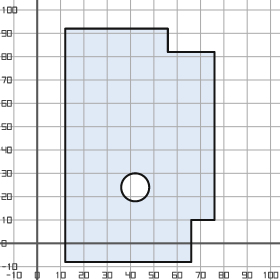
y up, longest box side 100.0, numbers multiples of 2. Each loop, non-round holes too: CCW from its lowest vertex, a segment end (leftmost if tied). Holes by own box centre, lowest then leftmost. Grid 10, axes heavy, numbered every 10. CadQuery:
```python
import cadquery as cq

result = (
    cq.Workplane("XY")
    .moveTo(12.0, -8.0)
    .lineTo(66.0, -8.0)
    .lineTo(66.0, 10.0)
    .lineTo(76.0, 10.0)
    .lineTo(76.0, 82.0)
    .lineTo(56.0, 82.0)
    .lineTo(56.0, 92.0)
    .lineTo(12.0, 92.0)
    .close()
    .moveTo(42.0, 24.0)
    .circle(6.0)
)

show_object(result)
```